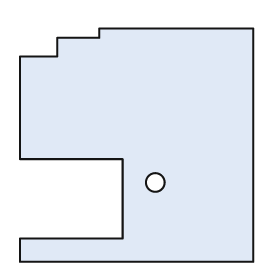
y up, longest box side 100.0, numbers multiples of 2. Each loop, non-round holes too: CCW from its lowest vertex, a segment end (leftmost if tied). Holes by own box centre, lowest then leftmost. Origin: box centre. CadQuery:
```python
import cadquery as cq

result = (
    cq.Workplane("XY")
    .moveTo(-50.0, -50.0)
    .lineTo(50.0, -50.0)
    .lineTo(50.0, 50.0)
    .lineTo(-16.0, 50.0)
    .lineTo(-16.0, 46.0)
    .lineTo(-34.0, 46.0)
    .lineTo(-34.0, 38.0)
    .lineTo(-50.0, 38.0)
    .lineTo(-50.0, -6.0)
    .lineTo(-6.0, -6.0)
    .lineTo(-6.0, -40.0)
    .lineTo(-50.0, -40.0)
    .close()
    .moveTo(8.0, -16.0)
    .circle(4.0)
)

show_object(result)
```